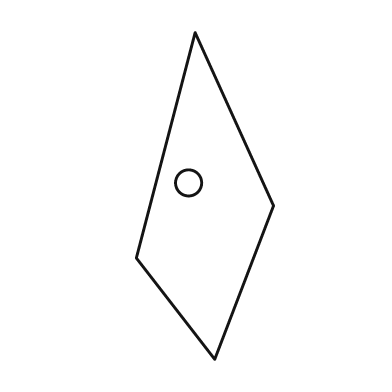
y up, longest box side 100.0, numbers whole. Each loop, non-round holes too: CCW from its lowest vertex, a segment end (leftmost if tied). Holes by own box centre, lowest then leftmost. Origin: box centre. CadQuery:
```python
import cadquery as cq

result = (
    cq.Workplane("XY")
    .moveTo(3.0, -50.0)
    .lineTo(21.0, -3.0)
    .lineTo(-3.0, 50.0)
    .lineTo(-21.0, -19.0)
    .close()
    .moveTo(-5.0, 4.0)
    .circle(4.0)
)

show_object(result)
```